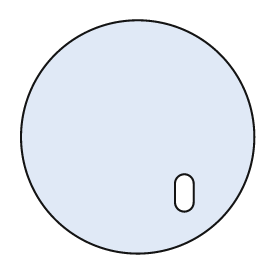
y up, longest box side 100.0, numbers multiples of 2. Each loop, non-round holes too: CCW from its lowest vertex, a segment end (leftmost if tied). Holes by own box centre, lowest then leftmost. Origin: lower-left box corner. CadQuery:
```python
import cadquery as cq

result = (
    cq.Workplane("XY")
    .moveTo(50.0, 50.0)
    .circle(50.0)
    .moveTo(66.0, 22.0)
    .threePointArc((70.0, 18.0), (74.0, 22.0))
    .lineTo(74.0, 30.0)
    .threePointArc((70.0, 34.0), (66.0, 30.0))
    .close()
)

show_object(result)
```